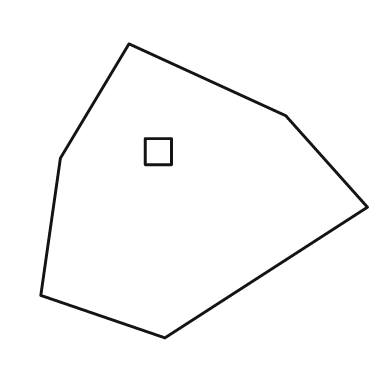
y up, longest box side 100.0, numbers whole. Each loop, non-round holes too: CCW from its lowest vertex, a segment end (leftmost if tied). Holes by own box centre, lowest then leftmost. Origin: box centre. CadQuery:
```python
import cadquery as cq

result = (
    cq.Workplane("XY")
    .moveTo(-12.0, -45.0)
    .lineTo(50.0, -5.0)
    .lineTo(25.0, 23.0)
    .lineTo(-23.0, 45.0)
    .lineTo(-44.0, 10.0)
    .lineTo(-50.0, -32.0)
    .close()
    .moveTo(-18.0, 8.0)
    .lineTo(-10.0, 8.0)
    .lineTo(-10.0, 16.0)
    .lineTo(-18.0, 16.0)
    .close()
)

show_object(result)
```